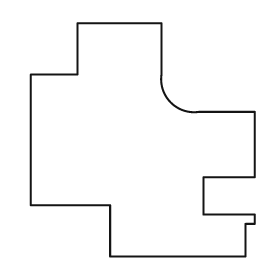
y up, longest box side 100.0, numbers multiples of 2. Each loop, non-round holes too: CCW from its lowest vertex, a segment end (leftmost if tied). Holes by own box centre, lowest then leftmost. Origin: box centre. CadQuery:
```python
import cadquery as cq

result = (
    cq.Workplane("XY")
    .moveTo(-14.0, -50.0)
    .lineTo(44.0, -50.0)
    .lineTo(44.0, -36.0)
    .lineTo(48.0, -36.0)
    .lineTo(48.0, -32.0)
    .lineTo(26.0, -32.0)
    .lineTo(26.0, -16.0)
    .lineTo(48.0, -16.0)
    .lineTo(48.0, 12.0)
    .lineTo(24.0, 12.0)
    .threePointArc((12.0, 16.0), (8.0, 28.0))
    .lineTo(8.0, 50.0)
    .lineTo(-28.0, 50.0)
    .lineTo(-28.0, 28.0)
    .lineTo(-48.0, 28.0)
    .lineTo(-48.0, -28.0)
    .lineTo(-14.0, -28.0)
    .close()
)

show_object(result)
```